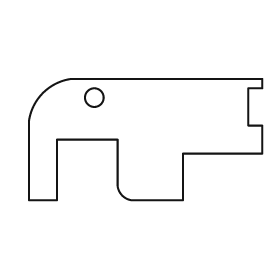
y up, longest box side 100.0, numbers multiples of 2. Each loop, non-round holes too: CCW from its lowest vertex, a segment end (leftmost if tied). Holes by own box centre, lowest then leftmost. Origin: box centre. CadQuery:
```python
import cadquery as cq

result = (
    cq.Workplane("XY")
    .moveTo(-50.0, -26.0)
    .lineTo(-38.0, -26.0)
    .lineTo(-38.0, 0.0)
    .lineTo(-12.0, 0.0)
    .lineTo(-12.0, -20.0)
    .threePointArc((-10.0, -24.0), (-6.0, -26.0))
    .lineTo(16.0, -26.0)
    .lineTo(16.0, -6.0)
    .lineTo(50.0, -6.0)
    .lineTo(50.0, 6.0)
    .lineTo(44.0, 6.0)
    .lineTo(44.0, 22.0)
    .lineTo(50.0, 22.0)
    .lineTo(50.0, 26.0)
    .lineTo(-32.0, 26.0)
    .threePointArc((-44.0, 20.0), (-50.0, 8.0))
    .close()
    .moveTo(-22.0, 18.0)
    .circle(4.0)
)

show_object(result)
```